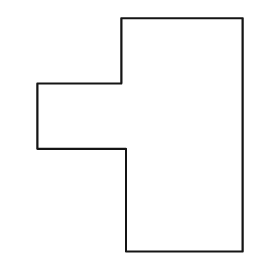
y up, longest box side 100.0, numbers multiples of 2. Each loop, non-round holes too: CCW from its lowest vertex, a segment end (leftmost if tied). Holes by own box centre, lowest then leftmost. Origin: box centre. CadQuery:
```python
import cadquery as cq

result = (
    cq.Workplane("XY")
    .moveTo(-6.0, -50.0)
    .lineTo(44.0, -50.0)
    .lineTo(44.0, 50.0)
    .lineTo(-8.0, 50.0)
    .lineTo(-8.0, 22.0)
    .lineTo(-44.0, 22.0)
    .lineTo(-44.0, -6.0)
    .lineTo(-6.0, -6.0)
    .close()
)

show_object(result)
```